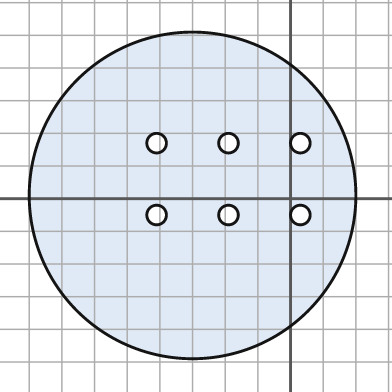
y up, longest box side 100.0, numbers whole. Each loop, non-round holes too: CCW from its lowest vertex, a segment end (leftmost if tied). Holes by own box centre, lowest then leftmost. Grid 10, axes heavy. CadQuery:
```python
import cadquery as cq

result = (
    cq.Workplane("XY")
    .moveTo(-30.0, 1.0)
    .circle(50.0)
    .moveTo(-41.0, -5.0)
    .circle(3.0)
    .moveTo(-19.0, -5.0)
    .circle(3.0)
    .moveTo(3.0, -5.0)
    .circle(3.0)
    .moveTo(-41.0, 17.0)
    .circle(3.0)
    .moveTo(-19.0, 17.0)
    .circle(3.0)
    .moveTo(3.0, 17.0)
    .circle(3.0)
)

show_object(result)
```